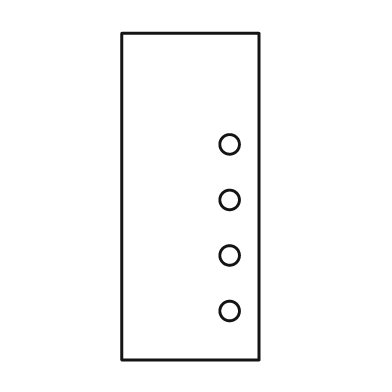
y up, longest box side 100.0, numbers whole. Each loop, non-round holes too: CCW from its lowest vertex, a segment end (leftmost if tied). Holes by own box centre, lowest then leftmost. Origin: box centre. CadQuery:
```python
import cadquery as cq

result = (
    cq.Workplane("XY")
    .moveTo(-21.0, -50.0)
    .lineTo(21.0, -50.0)
    .lineTo(21.0, 50.0)
    .lineTo(-21.0, 50.0)
    .close()
    .moveTo(12.0, -35.0)
    .circle(3.0)
    .moveTo(12.0, -18.0)
    .circle(3.0)
    .moveTo(12.0, -1.0)
    .circle(3.0)
    .moveTo(12.0, 16.0)
    .circle(3.0)
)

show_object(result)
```